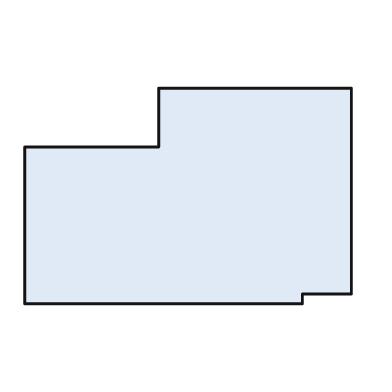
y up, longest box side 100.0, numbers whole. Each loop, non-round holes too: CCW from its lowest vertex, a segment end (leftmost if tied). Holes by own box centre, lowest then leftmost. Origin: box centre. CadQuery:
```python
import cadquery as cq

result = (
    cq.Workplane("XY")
    .moveTo(-50.0, -33.0)
    .lineTo(35.0, -33.0)
    .lineTo(35.0, -30.0)
    .lineTo(50.0, -30.0)
    .lineTo(50.0, 33.0)
    .lineTo(-9.0, 33.0)
    .lineTo(-9.0, 15.0)
    .lineTo(-50.0, 15.0)
    .close()
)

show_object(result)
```